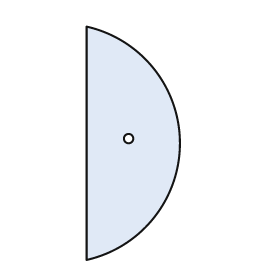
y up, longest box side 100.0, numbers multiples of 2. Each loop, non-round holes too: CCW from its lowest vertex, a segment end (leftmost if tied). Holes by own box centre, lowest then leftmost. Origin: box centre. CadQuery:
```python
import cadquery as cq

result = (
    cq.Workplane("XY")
    .moveTo(-20.0, -50.0)
    .threePointArc((20.0, 0.0), (-20.0, 50.0))
    .close()
    .moveTo(-2.0, 2.0)
    .circle(2.0)
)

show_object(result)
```